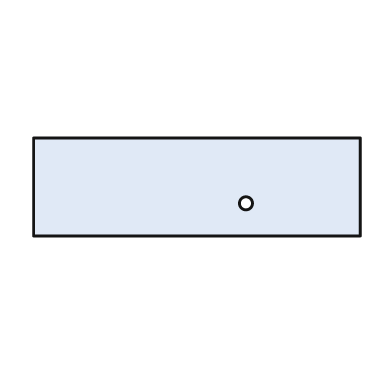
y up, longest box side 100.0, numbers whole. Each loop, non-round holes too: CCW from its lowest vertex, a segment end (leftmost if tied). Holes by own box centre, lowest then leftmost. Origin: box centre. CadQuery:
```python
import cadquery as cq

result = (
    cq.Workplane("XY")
    .moveTo(-50.0, -15.0)
    .lineTo(50.0, -15.0)
    .lineTo(50.0, 15.0)
    .lineTo(-50.0, 15.0)
    .close()
    .moveTo(15.0, -5.0)
    .circle(2.0)
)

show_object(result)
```